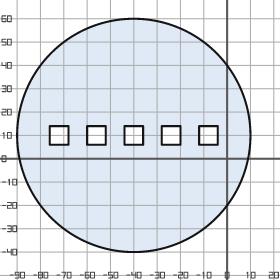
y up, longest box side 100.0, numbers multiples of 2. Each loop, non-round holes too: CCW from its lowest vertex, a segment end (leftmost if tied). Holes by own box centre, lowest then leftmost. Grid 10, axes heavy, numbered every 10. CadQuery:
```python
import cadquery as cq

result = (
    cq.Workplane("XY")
    .moveTo(-40.0, 10.0)
    .circle(50.0)
    .moveTo(-76.0, 6.0)
    .lineTo(-68.0, 6.0)
    .lineTo(-68.0, 14.0)
    .lineTo(-76.0, 14.0)
    .close()
    .moveTo(-60.0, 6.0)
    .lineTo(-52.0, 6.0)
    .lineTo(-52.0, 14.0)
    .lineTo(-60.0, 14.0)
    .close()
    .moveTo(-44.0, 6.0)
    .lineTo(-36.0, 6.0)
    .lineTo(-36.0, 14.0)
    .lineTo(-44.0, 14.0)
    .close()
    .moveTo(-28.0, 6.0)
    .lineTo(-20.0, 6.0)
    .lineTo(-20.0, 14.0)
    .lineTo(-28.0, 14.0)
    .close()
    .moveTo(-12.0, 6.0)
    .lineTo(-4.0, 6.0)
    .lineTo(-4.0, 14.0)
    .lineTo(-12.0, 14.0)
    .close()
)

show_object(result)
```